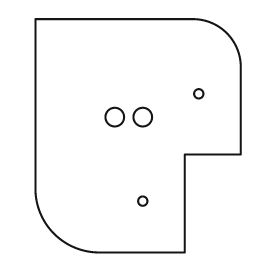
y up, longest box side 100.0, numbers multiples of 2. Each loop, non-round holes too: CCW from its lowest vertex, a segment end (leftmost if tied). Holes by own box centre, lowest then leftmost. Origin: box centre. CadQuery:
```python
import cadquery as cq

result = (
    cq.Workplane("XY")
    .moveTo(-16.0, -50.0)
    .lineTo(20.0, -50.0)
    .lineTo(20.0, -8.0)
    .lineTo(44.0, -8.0)
    .lineTo(44.0, 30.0)
    .threePointArc((38.0, 44.0), (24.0, 50.0))
    .lineTo(-44.0, 50.0)
    .lineTo(-44.0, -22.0)
    .threePointArc((-36.0, -42.0), (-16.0, -50.0))
    .close()
    .moveTo(2.0, -28.0)
    .circle(2.0)
    .moveTo(-10.0, 8.0)
    .circle(4.0)
    .moveTo(2.0, 8.0)
    .circle(4.0)
    .moveTo(26.0, 18.0)
    .circle(2.0)
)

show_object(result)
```